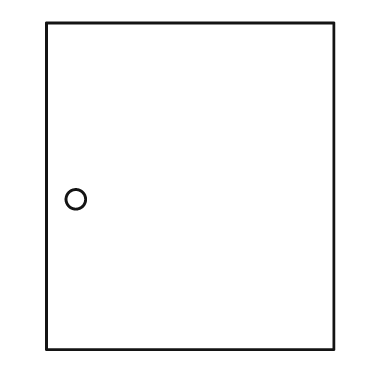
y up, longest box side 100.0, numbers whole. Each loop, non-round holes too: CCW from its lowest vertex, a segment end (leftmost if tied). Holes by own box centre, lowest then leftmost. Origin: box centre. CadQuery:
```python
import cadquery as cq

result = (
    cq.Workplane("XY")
    .moveTo(-44.0, -50.0)
    .lineTo(44.0, -50.0)
    .lineTo(44.0, 50.0)
    .lineTo(-44.0, 50.0)
    .close()
    .moveTo(-35.0, -4.0)
    .circle(3.0)
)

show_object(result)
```